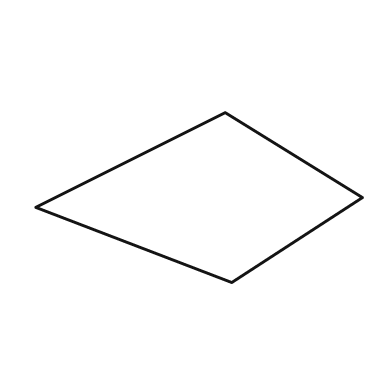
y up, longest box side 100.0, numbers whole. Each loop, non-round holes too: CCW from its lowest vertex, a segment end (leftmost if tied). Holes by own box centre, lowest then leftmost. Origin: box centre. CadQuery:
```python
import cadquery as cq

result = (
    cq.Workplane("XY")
    .moveTo(10.0, -26.0)
    .lineTo(50.0, 0.0)
    .lineTo(8.0, 26.0)
    .lineTo(-50.0, -3.0)
    .close()
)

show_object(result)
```